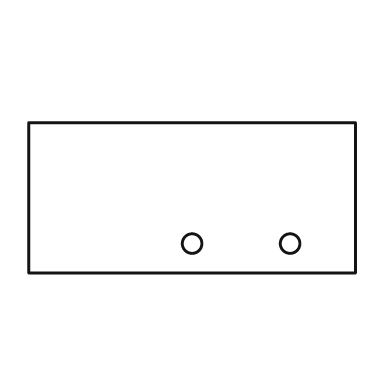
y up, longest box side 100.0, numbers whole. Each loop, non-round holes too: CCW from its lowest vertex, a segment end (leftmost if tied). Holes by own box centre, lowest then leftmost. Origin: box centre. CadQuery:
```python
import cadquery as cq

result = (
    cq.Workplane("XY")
    .moveTo(-50.0, -23.0)
    .lineTo(50.0, -23.0)
    .lineTo(50.0, 23.0)
    .lineTo(-50.0, 23.0)
    .close()
    .moveTo(0.0, -14.0)
    .circle(3.0)
    .moveTo(30.0, -14.0)
    .circle(3.0)
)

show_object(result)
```